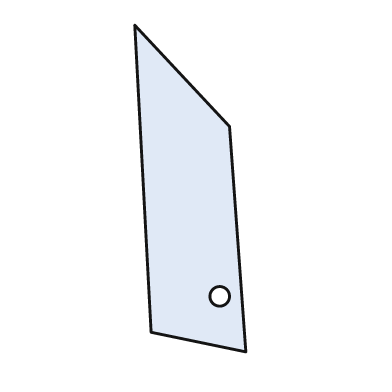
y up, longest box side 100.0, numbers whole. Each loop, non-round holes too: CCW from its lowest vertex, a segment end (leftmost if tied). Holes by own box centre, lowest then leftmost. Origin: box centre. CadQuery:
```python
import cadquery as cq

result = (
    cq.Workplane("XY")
    .moveTo(17.0, -50.0)
    .lineTo(12.0, 19.0)
    .lineTo(-17.0, 50.0)
    .lineTo(-12.0, -44.0)
    .close()
    .moveTo(9.0, -33.0)
    .circle(3.0)
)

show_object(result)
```